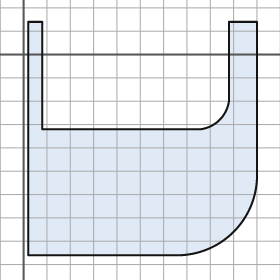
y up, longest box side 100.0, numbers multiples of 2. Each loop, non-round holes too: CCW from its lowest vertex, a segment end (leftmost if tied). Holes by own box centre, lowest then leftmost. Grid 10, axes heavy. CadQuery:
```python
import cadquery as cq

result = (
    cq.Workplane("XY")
    .moveTo(2.0, -86.0)
    .lineTo(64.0, -86.0)
    .threePointArc((90.0, -76.0), (100.0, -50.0))
    .lineTo(100.0, 14.0)
    .lineTo(88.0, 14.0)
    .lineTo(88.0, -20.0)
    .threePointArc((84.0, -28.0), (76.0, -32.0))
    .lineTo(8.0, -32.0)
    .lineTo(8.0, 14.0)
    .lineTo(2.0, 14.0)
    .close()
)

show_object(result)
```